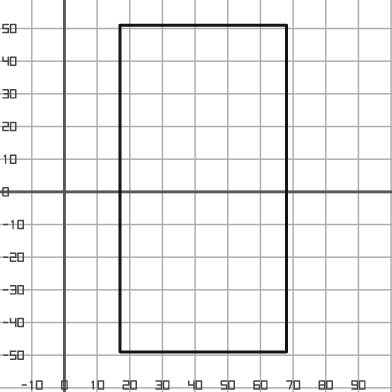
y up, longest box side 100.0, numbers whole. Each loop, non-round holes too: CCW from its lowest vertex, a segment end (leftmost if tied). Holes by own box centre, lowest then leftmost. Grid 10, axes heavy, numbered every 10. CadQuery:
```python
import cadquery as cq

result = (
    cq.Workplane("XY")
    .moveTo(17.0, -49.0)
    .lineTo(68.0, -49.0)
    .lineTo(68.0, 51.0)
    .lineTo(17.0, 51.0)
    .close()
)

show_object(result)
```